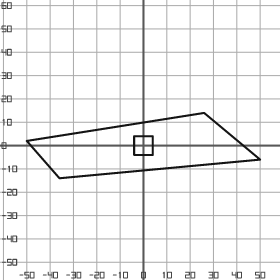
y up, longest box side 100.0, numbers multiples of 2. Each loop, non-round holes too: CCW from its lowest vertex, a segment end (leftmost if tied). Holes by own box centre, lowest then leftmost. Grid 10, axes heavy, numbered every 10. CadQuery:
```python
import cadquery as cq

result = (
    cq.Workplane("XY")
    .moveTo(-36.0, -14.0)
    .lineTo(50.0, -6.0)
    .lineTo(26.0, 14.0)
    .lineTo(-50.0, 2.0)
    .close()
    .moveTo(-4.0, -4.0)
    .lineTo(4.0, -4.0)
    .lineTo(4.0, 4.0)
    .lineTo(-4.0, 4.0)
    .close()
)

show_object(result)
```